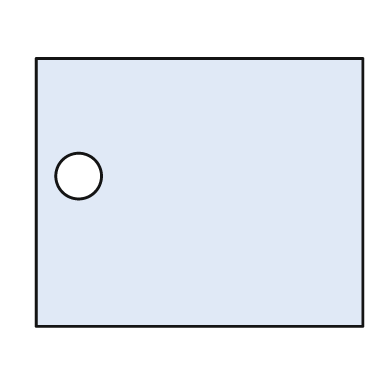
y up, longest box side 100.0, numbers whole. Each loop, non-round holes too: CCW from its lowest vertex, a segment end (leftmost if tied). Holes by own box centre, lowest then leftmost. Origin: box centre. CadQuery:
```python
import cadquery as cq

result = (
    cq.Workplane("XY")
    .moveTo(-50.0, -41.0)
    .lineTo(50.0, -41.0)
    .lineTo(50.0, 41.0)
    .lineTo(-50.0, 41.0)
    .close()
    .moveTo(-37.0, 5.0)
    .circle(7.0)
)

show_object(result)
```